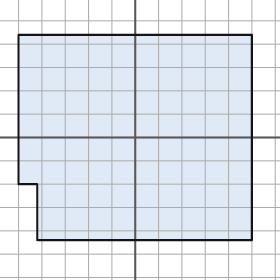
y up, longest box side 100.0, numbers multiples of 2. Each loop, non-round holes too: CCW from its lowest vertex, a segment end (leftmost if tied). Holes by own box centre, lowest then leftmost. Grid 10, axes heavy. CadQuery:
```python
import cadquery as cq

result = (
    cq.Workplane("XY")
    .moveTo(-42.0, -44.0)
    .lineTo(50.0, -44.0)
    .lineTo(50.0, 44.0)
    .lineTo(-50.0, 44.0)
    .lineTo(-50.0, -20.0)
    .lineTo(-42.0, -20.0)
    .close()
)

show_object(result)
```